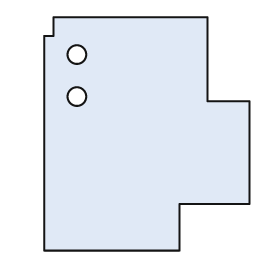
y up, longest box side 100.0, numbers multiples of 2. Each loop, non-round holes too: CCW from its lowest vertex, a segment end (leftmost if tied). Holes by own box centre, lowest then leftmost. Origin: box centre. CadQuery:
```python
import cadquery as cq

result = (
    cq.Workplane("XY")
    .moveTo(-44.0, -50.0)
    .lineTo(14.0, -50.0)
    .lineTo(14.0, -30.0)
    .lineTo(44.0, -30.0)
    .lineTo(44.0, 14.0)
    .lineTo(26.0, 14.0)
    .lineTo(26.0, 50.0)
    .lineTo(-40.0, 50.0)
    .lineTo(-40.0, 42.0)
    .lineTo(-44.0, 42.0)
    .close()
    .moveTo(-30.0, 16.0)
    .circle(4.0)
    .moveTo(-30.0, 34.0)
    .circle(4.0)
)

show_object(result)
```